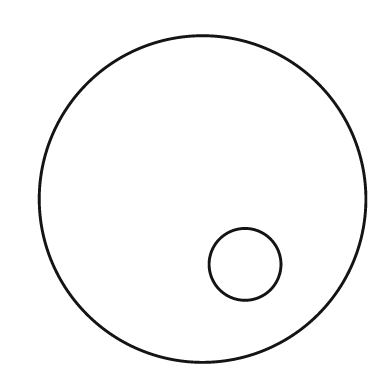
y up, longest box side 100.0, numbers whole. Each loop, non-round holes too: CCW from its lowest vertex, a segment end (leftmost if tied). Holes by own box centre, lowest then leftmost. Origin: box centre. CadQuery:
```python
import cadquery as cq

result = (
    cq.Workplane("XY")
    .moveTo(0.0, 0.0)
    .circle(50.0)
    .moveTo(13.0, -20.0)
    .circle(11.0)
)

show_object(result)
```